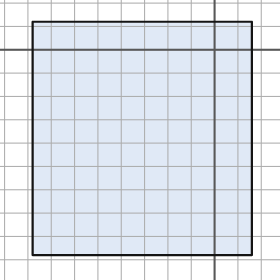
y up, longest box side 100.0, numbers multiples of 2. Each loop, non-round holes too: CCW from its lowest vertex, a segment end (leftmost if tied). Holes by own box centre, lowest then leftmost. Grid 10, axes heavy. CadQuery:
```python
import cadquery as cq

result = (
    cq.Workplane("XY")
    .moveTo(-78.0, -88.0)
    .lineTo(16.0, -88.0)
    .lineTo(16.0, 12.0)
    .lineTo(-78.0, 12.0)
    .close()
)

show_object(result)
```